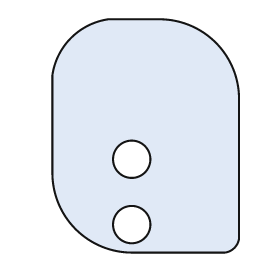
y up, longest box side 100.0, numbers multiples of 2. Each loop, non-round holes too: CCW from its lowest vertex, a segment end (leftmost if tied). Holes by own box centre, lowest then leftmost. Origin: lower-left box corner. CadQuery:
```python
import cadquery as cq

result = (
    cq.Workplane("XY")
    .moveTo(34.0, 0.0)
    .lineTo(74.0, 0.0)
    .threePointArc((78.0, 2.0), (80.0, 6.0))
    .lineTo(80.0, 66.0)
    .threePointArc((70.0, 90.0), (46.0, 100.0))
    .lineTo(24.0, 100.0)
    .threePointArc((8.0, 92.0), (0.0, 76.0))
    .lineTo(0.0, 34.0)
    .threePointArc((10.0, 10.0), (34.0, 0.0))
    .close()
    .moveTo(34.0, 12.0)
    .circle(8.0)
    .moveTo(34.0, 40.0)
    .circle(8.0)
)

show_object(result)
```